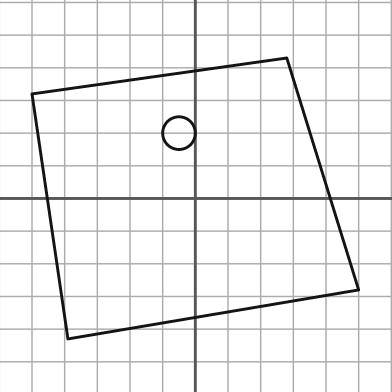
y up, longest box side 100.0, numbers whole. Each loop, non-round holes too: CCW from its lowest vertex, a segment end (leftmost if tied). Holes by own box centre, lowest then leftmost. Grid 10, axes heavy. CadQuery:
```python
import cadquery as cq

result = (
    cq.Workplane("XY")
    .moveTo(-39.0, -43.0)
    .lineTo(50.0, -28.0)
    .lineTo(28.0, 43.0)
    .lineTo(-50.0, 32.0)
    .close()
    .moveTo(-5.0, 20.0)
    .circle(5.0)
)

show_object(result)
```